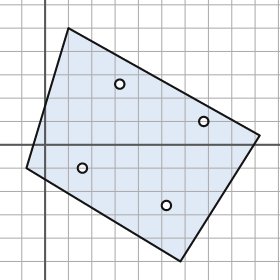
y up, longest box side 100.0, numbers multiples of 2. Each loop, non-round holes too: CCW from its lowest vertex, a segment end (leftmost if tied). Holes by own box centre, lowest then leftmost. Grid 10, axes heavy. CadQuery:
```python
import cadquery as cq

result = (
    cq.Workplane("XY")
    .moveTo(58.0, -50.0)
    .lineTo(92.0, 4.0)
    .lineTo(10.0, 50.0)
    .lineTo(-8.0, -10.0)
    .close()
    .moveTo(52.0, -26.0)
    .circle(2.0)
    .moveTo(16.0, -10.0)
    .circle(2.0)
    .moveTo(68.0, 10.0)
    .circle(2.0)
    .moveTo(32.0, 26.0)
    .circle(2.0)
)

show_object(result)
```